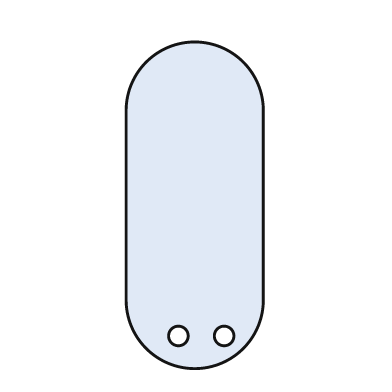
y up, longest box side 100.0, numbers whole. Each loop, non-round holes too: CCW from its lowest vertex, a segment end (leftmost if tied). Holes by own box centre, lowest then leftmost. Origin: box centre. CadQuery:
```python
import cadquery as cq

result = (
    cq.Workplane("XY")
    .moveTo(-21.0, -29.0)
    .threePointArc((0.0, -50.0), (21.0, -29.0))
    .lineTo(21.0, 29.0)
    .threePointArc((0.0, 50.0), (-21.0, 29.0))
    .close()
    .moveTo(-5.0, -40.0)
    .circle(3.0)
    .moveTo(9.0, -40.0)
    .circle(3.0)
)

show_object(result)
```